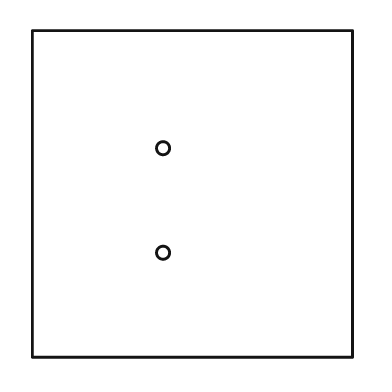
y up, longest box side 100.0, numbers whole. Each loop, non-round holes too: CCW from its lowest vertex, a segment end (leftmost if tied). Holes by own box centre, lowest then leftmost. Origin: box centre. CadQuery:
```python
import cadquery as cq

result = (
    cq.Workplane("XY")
    .moveTo(-49.0, -50.0)
    .lineTo(49.0, -50.0)
    .lineTo(49.0, 50.0)
    .lineTo(-49.0, 50.0)
    .close()
    .moveTo(-9.0, -18.0)
    .circle(2.0)
    .moveTo(-9.0, 14.0)
    .circle(2.0)
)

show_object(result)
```